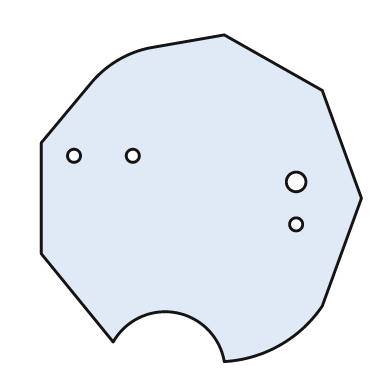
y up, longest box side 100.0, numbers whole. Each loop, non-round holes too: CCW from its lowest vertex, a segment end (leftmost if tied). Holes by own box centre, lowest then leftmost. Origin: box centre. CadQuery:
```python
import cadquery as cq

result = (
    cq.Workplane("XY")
    .moveTo(7.0, -50.0)
    .threePointArc((24.0, -45.0), (37.0, -33.0))
    .lineTo(49.0, 0.0)
    .lineTo(37.0, 33.0)
    .lineTo(7.0, 50.0)
    .lineTo(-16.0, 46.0)
    .threePointArc((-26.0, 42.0), (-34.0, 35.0))
    .lineTo(-49.0, 17.0)
    .lineTo(-49.0, -17.0)
    .lineTo(-27.0, -44.0)
    .threePointArc((-8.0, -35.0), (7.0, -50.0))
    .close()
    .moveTo(29.0, -8.0)
    .circle(2.0)
    .moveTo(29.0, 5.0)
    .circle(3.0)
    .moveTo(-39.0, 13.0)
    .circle(2.0)
    .moveTo(-21.0, 13.0)
    .circle(2.0)
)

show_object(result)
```